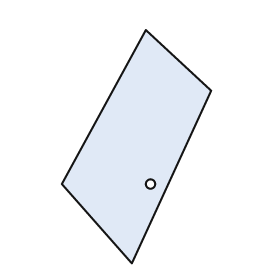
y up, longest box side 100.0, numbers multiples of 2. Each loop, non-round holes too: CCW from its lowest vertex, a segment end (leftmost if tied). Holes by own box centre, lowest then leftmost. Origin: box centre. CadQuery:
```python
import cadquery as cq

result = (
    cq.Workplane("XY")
    .moveTo(-2.0, -50.0)
    .lineTo(32.0, 24.0)
    .lineTo(4.0, 50.0)
    .lineTo(-32.0, -16.0)
    .close()
    .moveTo(6.0, -16.0)
    .circle(2.0)
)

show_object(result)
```